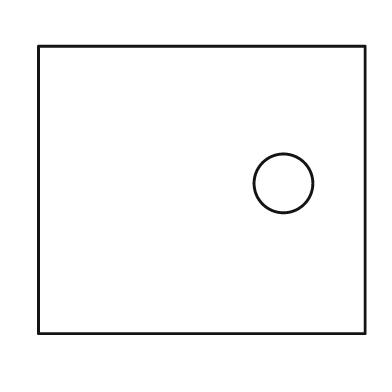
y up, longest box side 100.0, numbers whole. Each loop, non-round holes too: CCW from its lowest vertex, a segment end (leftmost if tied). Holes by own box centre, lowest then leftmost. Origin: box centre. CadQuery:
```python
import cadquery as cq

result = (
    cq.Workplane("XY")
    .moveTo(-50.0, -44.0)
    .lineTo(50.0, -44.0)
    .lineTo(50.0, 44.0)
    .lineTo(-50.0, 44.0)
    .close()
    .moveTo(25.0, 2.0)
    .circle(9.0)
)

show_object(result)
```